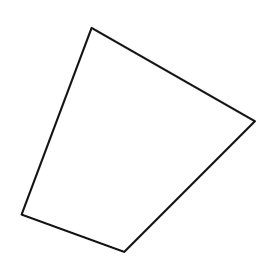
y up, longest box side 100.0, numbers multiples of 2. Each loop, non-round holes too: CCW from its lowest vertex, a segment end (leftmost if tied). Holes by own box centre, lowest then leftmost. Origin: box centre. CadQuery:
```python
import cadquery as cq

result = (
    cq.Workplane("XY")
    .moveTo(-6.0, -48.0)
    .lineTo(50.0, 8.0)
    .lineTo(-20.0, 48.0)
    .lineTo(-50.0, -32.0)
    .close()
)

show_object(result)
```